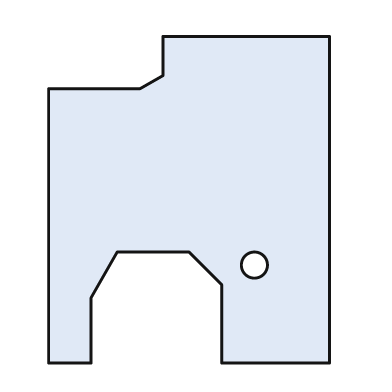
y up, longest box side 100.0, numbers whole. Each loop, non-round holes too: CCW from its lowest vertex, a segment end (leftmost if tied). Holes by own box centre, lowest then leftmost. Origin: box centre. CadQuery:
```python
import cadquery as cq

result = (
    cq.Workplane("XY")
    .moveTo(-43.0, -50.0)
    .lineTo(-30.0, -50.0)
    .lineTo(-30.0, -30.0)
    .lineTo(-22.0, -16.0)
    .lineTo(0.0, -16.0)
    .lineTo(10.0, -26.0)
    .lineTo(10.0, -50.0)
    .lineTo(43.0, -50.0)
    .lineTo(43.0, 50.0)
    .lineTo(-8.0, 50.0)
    .lineTo(-8.0, 38.0)
    .lineTo(-15.0, 34.0)
    .lineTo(-43.0, 34.0)
    .close()
    .moveTo(20.0, -20.0)
    .circle(4.0)
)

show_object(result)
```